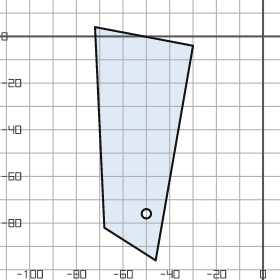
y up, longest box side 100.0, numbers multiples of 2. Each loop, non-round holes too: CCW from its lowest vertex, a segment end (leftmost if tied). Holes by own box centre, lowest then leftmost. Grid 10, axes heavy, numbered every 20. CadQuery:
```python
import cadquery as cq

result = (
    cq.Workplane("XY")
    .moveTo(-46.0, -96.0)
    .lineTo(-30.0, -4.0)
    .lineTo(-72.0, 4.0)
    .lineTo(-68.0, -82.0)
    .close()
    .moveTo(-50.0, -76.0)
    .circle(2.0)
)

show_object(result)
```